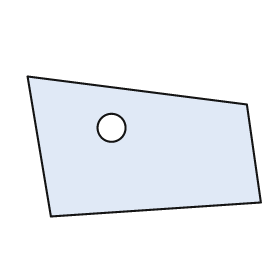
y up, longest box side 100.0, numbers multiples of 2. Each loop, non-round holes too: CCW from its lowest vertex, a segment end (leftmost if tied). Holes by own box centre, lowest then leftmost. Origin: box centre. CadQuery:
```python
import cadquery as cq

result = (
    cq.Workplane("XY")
    .moveTo(-40.0, -30.0)
    .lineTo(50.0, -24.0)
    .lineTo(44.0, 18.0)
    .lineTo(-50.0, 30.0)
    .close()
    .moveTo(-14.0, 8.0)
    .circle(6.0)
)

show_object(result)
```